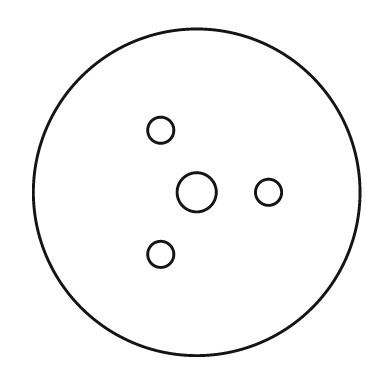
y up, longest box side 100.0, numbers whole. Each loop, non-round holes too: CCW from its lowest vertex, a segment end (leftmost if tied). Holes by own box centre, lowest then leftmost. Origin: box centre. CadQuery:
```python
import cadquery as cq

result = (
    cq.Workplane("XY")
    .moveTo(0.0, 0.0)
    .circle(50.0)
    .moveTo(-11.0, -19.0)
    .circle(4.0)
    .moveTo(0.0, 0.0)
    .circle(6.0)
    .moveTo(22.0, 0.0)
    .circle(4.0)
    .moveTo(-11.0, 19.0)
    .circle(4.0)
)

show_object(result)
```